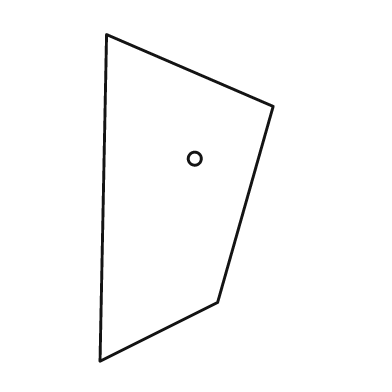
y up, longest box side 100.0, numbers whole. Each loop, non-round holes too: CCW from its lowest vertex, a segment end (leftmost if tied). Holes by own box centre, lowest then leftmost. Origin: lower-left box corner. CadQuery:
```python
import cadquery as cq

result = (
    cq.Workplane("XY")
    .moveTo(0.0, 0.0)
    .lineTo(36.0, 18.0)
    .lineTo(53.0, 78.0)
    .lineTo(2.0, 100.0)
    .close()
    .moveTo(29.0, 62.0)
    .circle(2.0)
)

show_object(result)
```